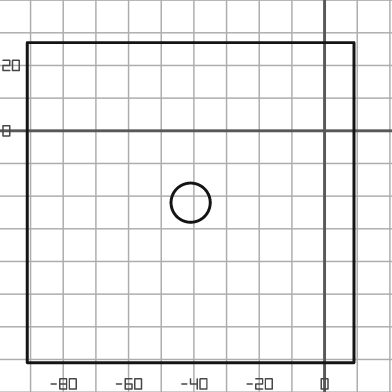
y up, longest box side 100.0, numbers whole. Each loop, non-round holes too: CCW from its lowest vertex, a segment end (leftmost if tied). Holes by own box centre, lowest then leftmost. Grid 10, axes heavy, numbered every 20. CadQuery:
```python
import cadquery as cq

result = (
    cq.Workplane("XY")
    .moveTo(-91.0, -71.0)
    .lineTo(9.0, -71.0)
    .lineTo(9.0, 27.0)
    .lineTo(-91.0, 27.0)
    .close()
    .moveTo(-41.0, -22.0)
    .circle(6.0)
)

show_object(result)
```